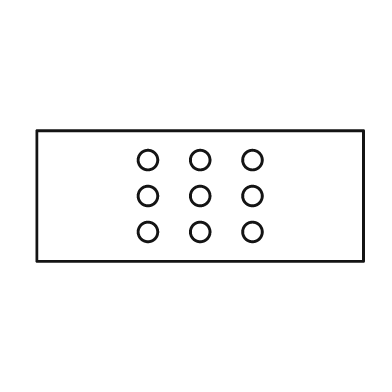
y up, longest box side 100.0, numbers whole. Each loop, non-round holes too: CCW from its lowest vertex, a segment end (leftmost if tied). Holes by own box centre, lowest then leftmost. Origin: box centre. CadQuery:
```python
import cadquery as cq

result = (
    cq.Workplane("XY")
    .moveTo(-50.0, -20.0)
    .lineTo(50.0, -20.0)
    .lineTo(50.0, 20.0)
    .lineTo(-50.0, 20.0)
    .close()
    .moveTo(-16.0, -11.0)
    .circle(3.0)
    .moveTo(0.0, -11.0)
    .circle(3.0)
    .moveTo(16.0, -11.0)
    .circle(3.0)
    .moveTo(-16.0, 0.0)
    .circle(3.0)
    .moveTo(0.0, 0.0)
    .circle(3.0)
    .moveTo(16.0, 0.0)
    .circle(3.0)
    .moveTo(-16.0, 11.0)
    .circle(3.0)
    .moveTo(0.0, 11.0)
    .circle(3.0)
    .moveTo(16.0, 11.0)
    .circle(3.0)
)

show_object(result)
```